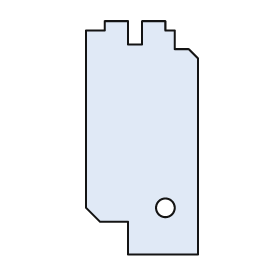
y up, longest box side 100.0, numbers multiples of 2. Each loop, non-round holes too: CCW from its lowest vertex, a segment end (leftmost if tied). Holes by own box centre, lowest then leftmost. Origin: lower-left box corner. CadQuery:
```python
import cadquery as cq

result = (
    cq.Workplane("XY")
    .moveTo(18.0, 0.0)
    .lineTo(48.0, 0.0)
    .lineTo(48.0, 84.0)
    .lineTo(44.0, 88.0)
    .lineTo(38.0, 88.0)
    .lineTo(38.0, 96.0)
    .lineTo(34.0, 96.0)
    .lineTo(34.0, 100.0)
    .lineTo(24.0, 100.0)
    .lineTo(24.0, 90.0)
    .lineTo(18.0, 90.0)
    .lineTo(18.0, 100.0)
    .lineTo(8.0, 100.0)
    .lineTo(8.0, 96.0)
    .lineTo(0.0, 96.0)
    .lineTo(0.0, 20.0)
    .lineTo(6.0, 14.0)
    .lineTo(18.0, 14.0)
    .close()
    .moveTo(34.0, 20.0)
    .circle(4.0)
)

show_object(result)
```